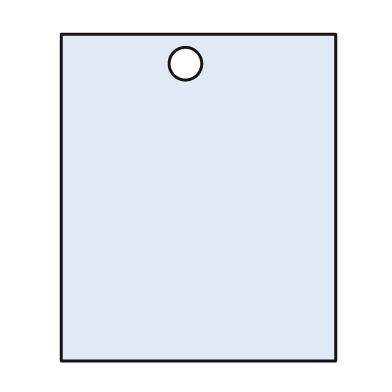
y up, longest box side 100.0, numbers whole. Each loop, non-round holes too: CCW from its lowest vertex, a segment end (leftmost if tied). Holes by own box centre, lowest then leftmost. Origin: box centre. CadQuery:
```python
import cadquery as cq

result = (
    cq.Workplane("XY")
    .moveTo(-42.0, -50.0)
    .lineTo(42.0, -50.0)
    .lineTo(42.0, 50.0)
    .lineTo(-42.0, 50.0)
    .close()
    .moveTo(-4.0, 41.0)
    .circle(5.0)
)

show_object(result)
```